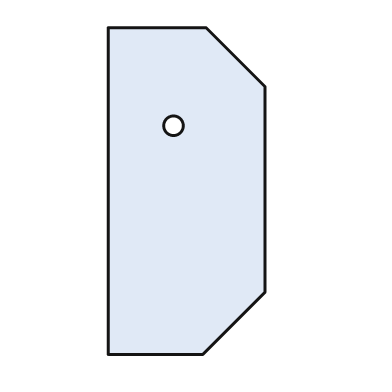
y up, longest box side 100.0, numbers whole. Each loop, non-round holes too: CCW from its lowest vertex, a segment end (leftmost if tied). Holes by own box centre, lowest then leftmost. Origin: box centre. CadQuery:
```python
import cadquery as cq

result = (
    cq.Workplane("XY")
    .moveTo(-24.0, -50.0)
    .lineTo(5.0, -50.0)
    .lineTo(24.0, -31.0)
    .lineTo(24.0, 32.0)
    .lineTo(6.0, 50.0)
    .lineTo(-24.0, 50.0)
    .close()
    .moveTo(-4.0, 20.0)
    .circle(3.0)
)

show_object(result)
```